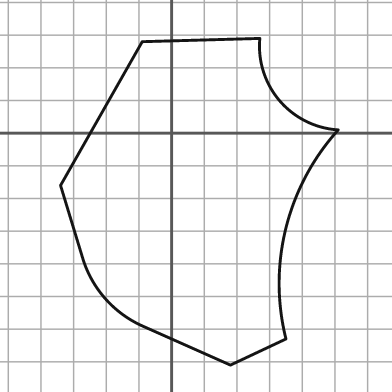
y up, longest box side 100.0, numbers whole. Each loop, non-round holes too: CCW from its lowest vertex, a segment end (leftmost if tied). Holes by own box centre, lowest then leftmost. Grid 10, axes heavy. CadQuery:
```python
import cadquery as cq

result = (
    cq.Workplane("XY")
    .moveTo(18.0, -71.0)
    .lineTo(35.0, -63.0)
    .threePointArc((35.0, -29.0), (51.0, 1.0))
    .threePointArc((33.0, 10.0), (27.0, 29.0))
    .lineTo(-9.0, 28.0)
    .lineTo(-34.0, -16.0)
    .lineTo(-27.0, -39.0)
    .threePointArc((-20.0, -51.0), (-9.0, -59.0))
    .close()
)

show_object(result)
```